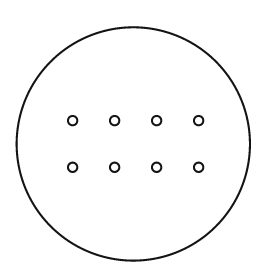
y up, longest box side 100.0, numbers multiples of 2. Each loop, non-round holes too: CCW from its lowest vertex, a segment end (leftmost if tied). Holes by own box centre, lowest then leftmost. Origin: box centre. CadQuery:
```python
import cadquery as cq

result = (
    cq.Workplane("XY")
    .moveTo(0.0, 0.0)
    .circle(50.0)
    .moveTo(-26.0, -10.0)
    .circle(2.0)
    .moveTo(-8.0, -10.0)
    .circle(2.0)
    .moveTo(10.0, -10.0)
    .circle(2.0)
    .moveTo(28.0, -10.0)
    .circle(2.0)
    .moveTo(-26.0, 10.0)
    .circle(2.0)
    .moveTo(-8.0, 10.0)
    .circle(2.0)
    .moveTo(10.0, 10.0)
    .circle(2.0)
    .moveTo(28.0, 10.0)
    .circle(2.0)
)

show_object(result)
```